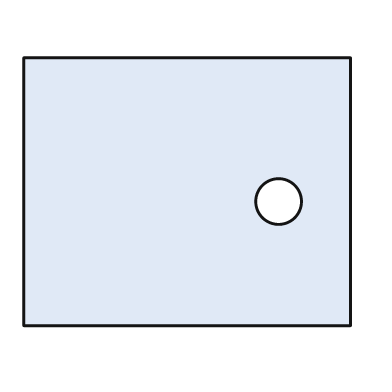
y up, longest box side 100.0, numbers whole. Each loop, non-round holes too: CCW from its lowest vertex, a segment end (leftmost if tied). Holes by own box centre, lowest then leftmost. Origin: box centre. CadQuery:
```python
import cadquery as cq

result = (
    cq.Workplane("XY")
    .moveTo(-50.0, -41.0)
    .lineTo(50.0, -41.0)
    .lineTo(50.0, 41.0)
    .lineTo(-50.0, 41.0)
    .close()
    .moveTo(28.0, -3.0)
    .circle(7.0)
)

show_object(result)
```